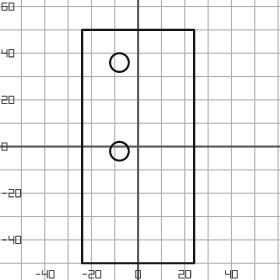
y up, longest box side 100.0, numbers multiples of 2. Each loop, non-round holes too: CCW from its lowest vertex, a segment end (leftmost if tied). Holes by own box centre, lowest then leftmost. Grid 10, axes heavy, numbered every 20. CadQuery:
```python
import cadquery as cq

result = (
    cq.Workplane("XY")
    .moveTo(-24.0, -50.0)
    .lineTo(24.0, -50.0)
    .lineTo(24.0, 50.0)
    .lineTo(-24.0, 50.0)
    .close()
    .moveTo(-8.0, -2.0)
    .circle(4.0)
    .moveTo(-8.0, 36.0)
    .circle(4.0)
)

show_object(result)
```